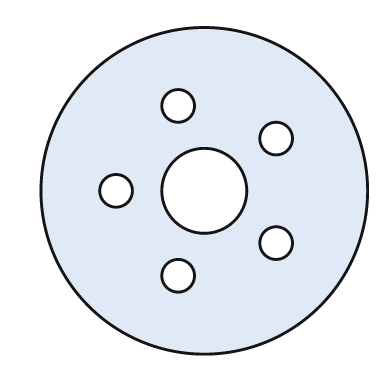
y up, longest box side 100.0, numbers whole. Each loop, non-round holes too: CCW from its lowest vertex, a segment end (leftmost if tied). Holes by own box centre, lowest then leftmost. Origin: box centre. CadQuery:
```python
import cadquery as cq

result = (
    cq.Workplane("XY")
    .moveTo(0.0, 0.0)
    .circle(50.0)
    .moveTo(-8.0, -26.0)
    .circle(5.0)
    .moveTo(22.0, -16.0)
    .circle(5.0)
    .moveTo(-27.0, 0.0)
    .circle(5.0)
    .moveTo(0.0, 0.0)
    .circle(13.0)
    .moveTo(22.0, 16.0)
    .circle(5.0)
    .moveTo(-8.0, 26.0)
    .circle(5.0)
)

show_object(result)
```